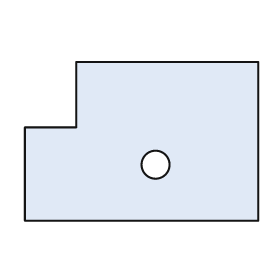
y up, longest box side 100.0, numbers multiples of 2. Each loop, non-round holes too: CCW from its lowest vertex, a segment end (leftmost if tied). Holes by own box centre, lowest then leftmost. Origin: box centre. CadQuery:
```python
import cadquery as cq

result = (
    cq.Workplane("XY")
    .moveTo(-50.0, -34.0)
    .lineTo(50.0, -34.0)
    .lineTo(50.0, 34.0)
    .lineTo(-28.0, 34.0)
    .lineTo(-28.0, 6.0)
    .lineTo(-50.0, 6.0)
    .close()
    .moveTo(6.0, -10.0)
    .circle(6.0)
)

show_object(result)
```